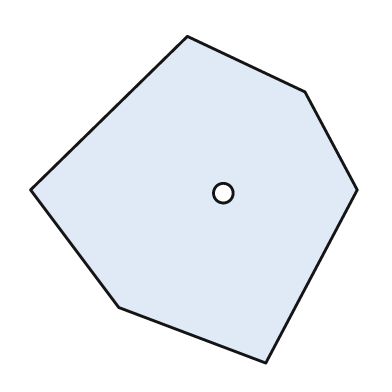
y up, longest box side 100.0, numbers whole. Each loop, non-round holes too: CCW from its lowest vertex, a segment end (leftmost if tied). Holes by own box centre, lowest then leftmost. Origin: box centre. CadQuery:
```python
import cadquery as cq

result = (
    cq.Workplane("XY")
    .moveTo(22.0, -50.0)
    .lineTo(50.0, 3.0)
    .lineTo(34.0, 33.0)
    .lineTo(-2.0, 50.0)
    .lineTo(-50.0, 3.0)
    .lineTo(-23.0, -33.0)
    .close()
    .moveTo(9.0, 2.0)
    .circle(3.0)
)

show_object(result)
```